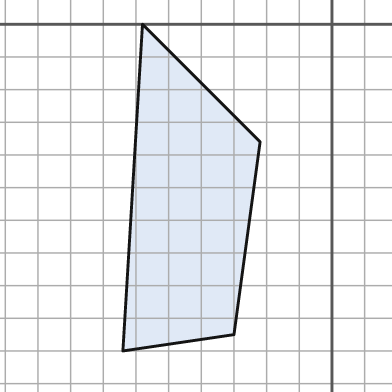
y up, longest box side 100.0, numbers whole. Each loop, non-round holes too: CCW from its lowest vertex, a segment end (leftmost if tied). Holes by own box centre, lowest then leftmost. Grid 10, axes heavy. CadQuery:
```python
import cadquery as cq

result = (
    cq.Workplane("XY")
    .moveTo(-64.0, -100.0)
    .lineTo(-30.0, -95.0)
    .lineTo(-22.0, -36.0)
    .lineTo(-58.0, 0.0)
    .close()
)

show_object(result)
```